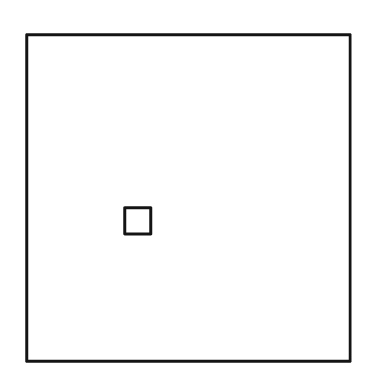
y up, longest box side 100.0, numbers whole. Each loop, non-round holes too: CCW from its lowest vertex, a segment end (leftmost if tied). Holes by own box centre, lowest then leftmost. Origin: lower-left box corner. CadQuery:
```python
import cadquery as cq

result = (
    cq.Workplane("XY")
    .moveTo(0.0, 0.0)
    .lineTo(99.0, 0.0)
    .lineTo(99.0, 100.0)
    .lineTo(0.0, 100.0)
    .close()
    .moveTo(30.0, 39.0)
    .lineTo(38.0, 39.0)
    .lineTo(38.0, 47.0)
    .lineTo(30.0, 47.0)
    .close()
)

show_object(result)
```